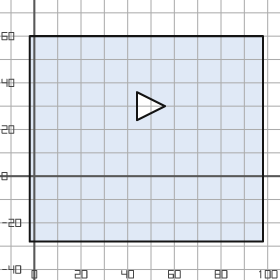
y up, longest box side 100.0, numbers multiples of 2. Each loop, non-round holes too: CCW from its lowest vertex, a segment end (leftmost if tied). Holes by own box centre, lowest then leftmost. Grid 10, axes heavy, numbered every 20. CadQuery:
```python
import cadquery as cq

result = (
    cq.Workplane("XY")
    .moveTo(-2.0, -28.0)
    .lineTo(98.0, -28.0)
    .lineTo(98.0, 60.0)
    .lineTo(-2.0, 60.0)
    .close()
    .moveTo(44.0, 24.0)
    .lineTo(56.0, 30.0)
    .lineTo(44.0, 36.0)
    .close()
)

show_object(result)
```